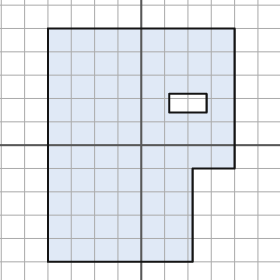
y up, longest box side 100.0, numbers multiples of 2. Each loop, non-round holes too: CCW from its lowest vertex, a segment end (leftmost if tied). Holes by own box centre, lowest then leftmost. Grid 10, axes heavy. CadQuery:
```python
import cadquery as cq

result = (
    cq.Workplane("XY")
    .moveTo(-40.0, -50.0)
    .lineTo(22.0, -50.0)
    .lineTo(22.0, -10.0)
    .lineTo(40.0, -10.0)
    .lineTo(40.0, 50.0)
    .lineTo(-40.0, 50.0)
    .close()
    .moveTo(12.0, 14.0)
    .lineTo(28.0, 14.0)
    .lineTo(28.0, 22.0)
    .lineTo(12.0, 22.0)
    .close()
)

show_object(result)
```